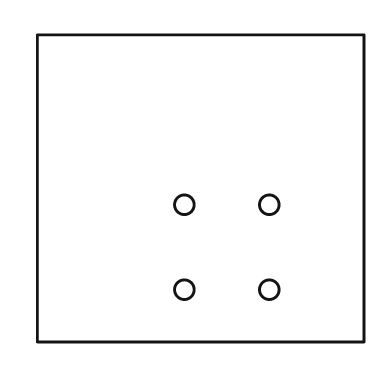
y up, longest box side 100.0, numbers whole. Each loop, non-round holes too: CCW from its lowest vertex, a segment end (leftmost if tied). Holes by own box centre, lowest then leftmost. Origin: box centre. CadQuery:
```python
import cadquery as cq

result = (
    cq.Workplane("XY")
    .moveTo(-50.0, -47.0)
    .lineTo(50.0, -47.0)
    .lineTo(50.0, 47.0)
    .lineTo(-50.0, 47.0)
    .close()
    .moveTo(-5.0, -31.0)
    .circle(3.0)
    .moveTo(21.0, -31.0)
    .circle(3.0)
    .moveTo(-5.0, -5.0)
    .circle(3.0)
    .moveTo(21.0, -5.0)
    .circle(3.0)
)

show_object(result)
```